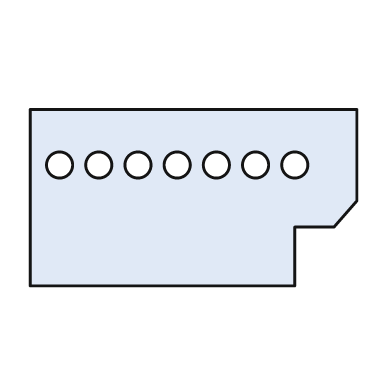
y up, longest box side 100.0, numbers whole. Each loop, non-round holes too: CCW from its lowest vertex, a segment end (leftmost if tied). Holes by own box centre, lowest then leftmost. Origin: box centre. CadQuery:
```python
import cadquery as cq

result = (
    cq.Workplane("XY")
    .moveTo(-50.0, -27.0)
    .lineTo(31.0, -27.0)
    .lineTo(31.0, -9.0)
    .lineTo(43.0, -9.0)
    .lineTo(50.0, -1.0)
    .lineTo(50.0, 27.0)
    .lineTo(-50.0, 27.0)
    .close()
    .moveTo(-41.0, 10.0)
    .circle(4.0)
    .moveTo(-29.0, 10.0)
    .circle(4.0)
    .moveTo(-17.0, 10.0)
    .circle(4.0)
    .moveTo(-5.0, 10.0)
    .circle(4.0)
    .moveTo(7.0, 10.0)
    .circle(4.0)
    .moveTo(19.0, 10.0)
    .circle(4.0)
    .moveTo(31.0, 10.0)
    .circle(4.0)
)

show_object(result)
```